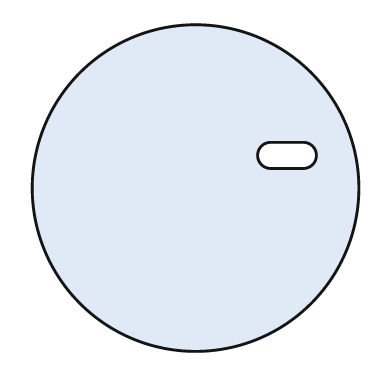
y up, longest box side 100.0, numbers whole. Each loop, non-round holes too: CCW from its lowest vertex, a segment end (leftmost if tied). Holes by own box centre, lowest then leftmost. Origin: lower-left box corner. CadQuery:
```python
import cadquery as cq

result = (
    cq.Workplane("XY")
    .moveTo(50.0, 50.0)
    .circle(50.0)
    .moveTo(73.0, 56.0)
    .lineTo(83.0, 56.0)
    .threePointArc((87.0, 60.0), (83.0, 64.0))
    .lineTo(73.0, 64.0)
    .threePointArc((69.0, 60.0), (73.0, 56.0))
    .close()
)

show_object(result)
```